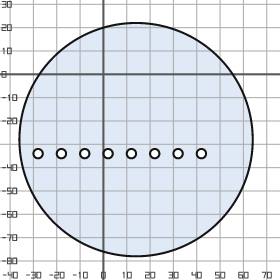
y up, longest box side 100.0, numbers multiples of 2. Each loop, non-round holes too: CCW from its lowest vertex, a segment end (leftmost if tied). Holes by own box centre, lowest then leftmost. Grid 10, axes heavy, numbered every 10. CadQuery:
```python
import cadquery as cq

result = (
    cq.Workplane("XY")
    .moveTo(14.0, -28.0)
    .circle(50.0)
    .moveTo(-28.0, -34.0)
    .circle(2.0)
    .moveTo(-18.0, -34.0)
    .circle(2.0)
    .moveTo(-8.0, -34.0)
    .circle(2.0)
    .moveTo(2.0, -34.0)
    .circle(2.0)
    .moveTo(12.0, -34.0)
    .circle(2.0)
    .moveTo(22.0, -34.0)
    .circle(2.0)
    .moveTo(32.0, -34.0)
    .circle(2.0)
    .moveTo(42.0, -34.0)
    .circle(2.0)
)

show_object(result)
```